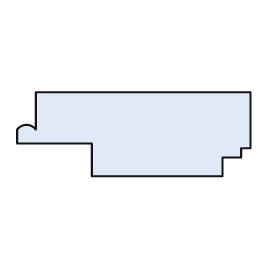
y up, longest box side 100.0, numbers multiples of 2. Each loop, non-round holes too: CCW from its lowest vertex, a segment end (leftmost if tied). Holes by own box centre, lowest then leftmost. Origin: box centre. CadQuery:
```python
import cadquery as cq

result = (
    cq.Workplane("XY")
    .moveTo(-18.0, -18.0)
    .lineTo(38.0, -18.0)
    .lineTo(38.0, -10.0)
    .lineTo(46.0, -10.0)
    .lineTo(46.0, -6.0)
    .lineTo(50.0, -6.0)
    .lineTo(50.0, 18.0)
    .lineTo(-42.0, 18.0)
    .lineTo(-42.0, 2.0)
    .threePointArc((-46.0, 4.0), (-50.0, 2.0))
    .lineTo(-50.0, -4.0)
    .lineTo(-18.0, -4.0)
    .close()
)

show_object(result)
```